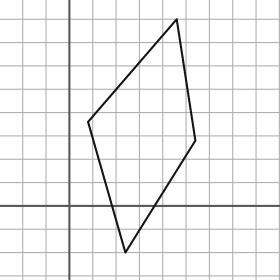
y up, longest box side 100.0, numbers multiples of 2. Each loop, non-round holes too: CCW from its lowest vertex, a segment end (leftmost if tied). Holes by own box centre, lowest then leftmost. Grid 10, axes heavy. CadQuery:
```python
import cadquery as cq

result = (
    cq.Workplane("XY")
    .moveTo(24.0, -20.0)
    .lineTo(54.0, 28.0)
    .lineTo(46.0, 80.0)
    .lineTo(8.0, 36.0)
    .close()
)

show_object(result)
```